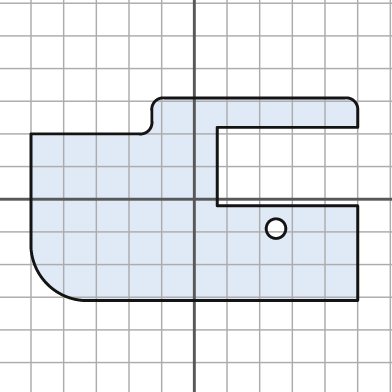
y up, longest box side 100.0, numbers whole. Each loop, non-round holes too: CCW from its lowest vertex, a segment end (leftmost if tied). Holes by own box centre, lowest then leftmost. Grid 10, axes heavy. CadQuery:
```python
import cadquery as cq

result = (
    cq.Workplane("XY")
    .moveTo(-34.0, -31.0)
    .lineTo(50.0, -31.0)
    .lineTo(50.0, -2.0)
    .lineTo(7.0, -2.0)
    .lineTo(7.0, 22.0)
    .lineTo(50.0, 22.0)
    .lineTo(50.0, 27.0)
    .threePointArc((49.0, 30.0), (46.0, 31.0))
    .lineTo(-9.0, 31.0)
    .threePointArc((-12.0, 30.0), (-13.0, 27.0))
    .lineTo(-13.0, 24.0)
    .threePointArc((-14.0, 21.0), (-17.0, 20.0))
    .lineTo(-50.0, 20.0)
    .lineTo(-50.0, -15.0)
    .threePointArc((-45.0, -26.0), (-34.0, -31.0))
    .close()
    .moveTo(25.0, -9.0)
    .circle(3.0)
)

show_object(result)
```